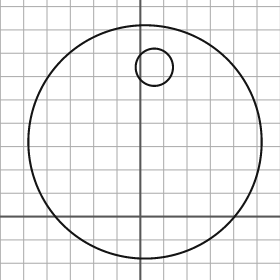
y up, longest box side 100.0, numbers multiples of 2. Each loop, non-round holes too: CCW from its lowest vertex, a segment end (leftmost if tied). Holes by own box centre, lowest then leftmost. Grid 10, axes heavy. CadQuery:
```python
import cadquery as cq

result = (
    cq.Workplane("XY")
    .moveTo(2.0, 32.0)
    .circle(50.0)
    .moveTo(6.0, 64.0)
    .circle(8.0)
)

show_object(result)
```